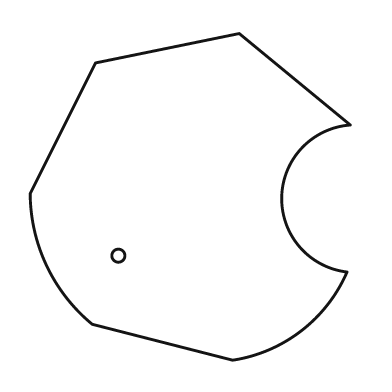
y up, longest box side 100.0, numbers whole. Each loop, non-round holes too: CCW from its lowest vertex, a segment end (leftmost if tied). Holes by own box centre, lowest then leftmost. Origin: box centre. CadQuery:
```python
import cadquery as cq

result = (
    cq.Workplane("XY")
    .moveTo(13.0, -50.0)
    .threePointArc((34.0, -41.0), (48.0, -23.0))
    .threePointArc((28.0, 0.0), (49.0, 22.0))
    .lineTo(15.0, 50.0)
    .lineTo(-29.0, 41.0)
    .lineTo(-49.0, 1.0)
    .threePointArc((-44.0, -21.0), (-30.0, -39.0))
    .close()
    .moveTo(-22.0, -18.0)
    .circle(2.0)
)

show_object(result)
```